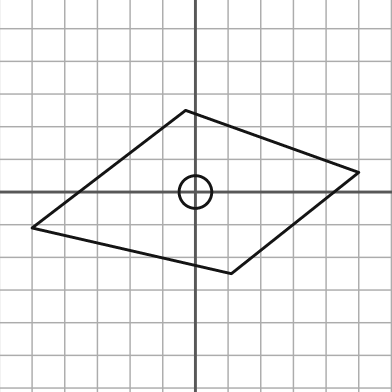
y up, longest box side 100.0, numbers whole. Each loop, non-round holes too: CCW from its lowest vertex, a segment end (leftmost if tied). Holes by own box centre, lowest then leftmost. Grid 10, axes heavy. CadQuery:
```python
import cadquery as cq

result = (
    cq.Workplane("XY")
    .moveTo(11.0, -25.0)
    .lineTo(50.0, 6.0)
    .lineTo(-3.0, 25.0)
    .lineTo(-50.0, -11.0)
    .close()
    .moveTo(0.0, 0.0)
    .circle(5.0)
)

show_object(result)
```